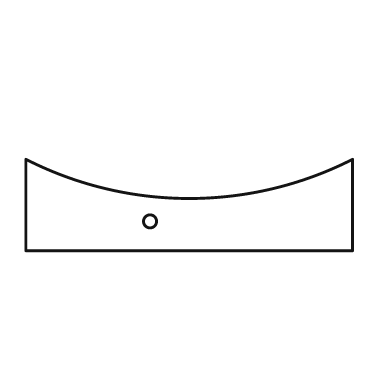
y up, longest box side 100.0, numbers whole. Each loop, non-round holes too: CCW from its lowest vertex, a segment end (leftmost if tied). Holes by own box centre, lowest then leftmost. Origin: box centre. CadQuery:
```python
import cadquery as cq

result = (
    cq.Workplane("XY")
    .moveTo(-50.0, -14.0)
    .lineTo(50.0, -14.0)
    .lineTo(50.0, 14.0)
    .threePointArc((0.0, 2.0), (-50.0, 14.0))
    .close()
    .moveTo(-12.0, -5.0)
    .circle(2.0)
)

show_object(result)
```